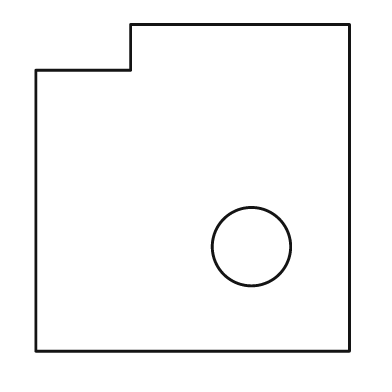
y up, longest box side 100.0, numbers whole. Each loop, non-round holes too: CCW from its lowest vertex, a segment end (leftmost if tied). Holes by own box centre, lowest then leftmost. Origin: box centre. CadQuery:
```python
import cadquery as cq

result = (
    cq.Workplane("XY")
    .moveTo(-48.0, -50.0)
    .lineTo(48.0, -50.0)
    .lineTo(48.0, 50.0)
    .lineTo(-19.0, 50.0)
    .lineTo(-19.0, 36.0)
    .lineTo(-48.0, 36.0)
    .close()
    .moveTo(18.0, -18.0)
    .circle(12.0)
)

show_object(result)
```